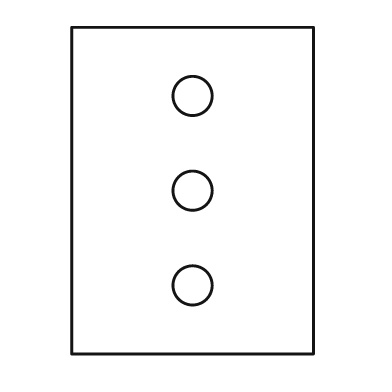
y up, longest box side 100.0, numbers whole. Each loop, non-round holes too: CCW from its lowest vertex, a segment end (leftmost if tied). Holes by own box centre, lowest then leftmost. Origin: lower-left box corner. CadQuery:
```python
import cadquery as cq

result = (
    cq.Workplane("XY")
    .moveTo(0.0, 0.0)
    .lineTo(74.0, 0.0)
    .lineTo(74.0, 100.0)
    .lineTo(0.0, 100.0)
    .close()
    .moveTo(37.0, 21.0)
    .circle(6.0)
    .moveTo(37.0, 50.0)
    .circle(6.0)
    .moveTo(37.0, 79.0)
    .circle(6.0)
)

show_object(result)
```